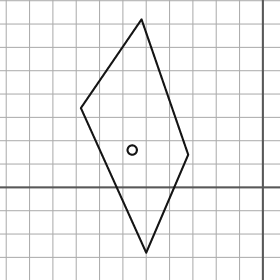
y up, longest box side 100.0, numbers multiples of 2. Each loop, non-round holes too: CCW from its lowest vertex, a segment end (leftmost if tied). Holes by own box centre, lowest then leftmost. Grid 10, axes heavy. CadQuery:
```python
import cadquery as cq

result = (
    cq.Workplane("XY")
    .moveTo(-50.0, -28.0)
    .lineTo(-32.0, 14.0)
    .lineTo(-52.0, 72.0)
    .lineTo(-78.0, 34.0)
    .close()
    .moveTo(-56.0, 16.0)
    .circle(2.0)
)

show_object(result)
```